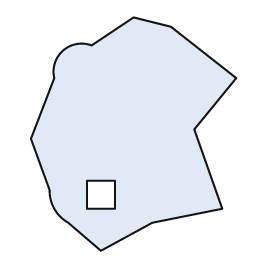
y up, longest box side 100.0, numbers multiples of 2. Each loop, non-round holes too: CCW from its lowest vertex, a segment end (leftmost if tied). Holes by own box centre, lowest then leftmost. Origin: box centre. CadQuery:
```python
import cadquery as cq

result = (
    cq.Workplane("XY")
    .moveTo(-14.0, -50.0)
    .lineTo(8.0, -38.0)
    .lineTo(38.0, -32.0)
    .lineTo(26.0, 2.0)
    .lineTo(44.0, 24.0)
    .lineTo(16.0, 46.0)
    .lineTo(0.0, 50.0)
    .lineTo(-18.0, 38.0)
    .threePointArc((-30.0, 36.0), (-34.0, 24.0))
    .lineTo(-44.0, -2.0)
    .lineTo(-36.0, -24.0)
    .threePointArc((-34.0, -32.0), (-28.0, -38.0))
    .close()
    .moveTo(-20.0, -32.0)
    .lineTo(-8.0, -32.0)
    .lineTo(-8.0, -20.0)
    .lineTo(-20.0, -20.0)
    .close()
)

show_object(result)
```